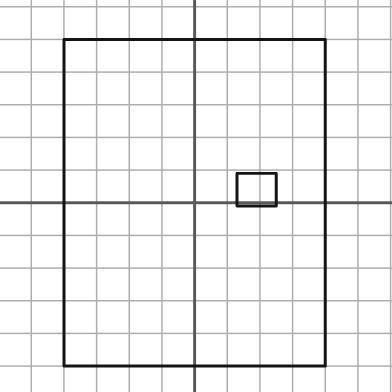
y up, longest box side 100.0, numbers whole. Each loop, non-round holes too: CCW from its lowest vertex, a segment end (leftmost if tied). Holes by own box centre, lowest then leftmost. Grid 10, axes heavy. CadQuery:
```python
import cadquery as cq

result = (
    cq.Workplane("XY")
    .moveTo(-40.0, -50.0)
    .lineTo(40.0, -50.0)
    .lineTo(40.0, 50.0)
    .lineTo(-40.0, 50.0)
    .close()
    .moveTo(13.0, -1.0)
    .lineTo(25.0, -1.0)
    .lineTo(25.0, 9.0)
    .lineTo(13.0, 9.0)
    .close()
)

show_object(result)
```